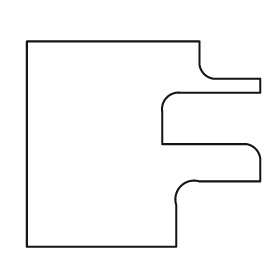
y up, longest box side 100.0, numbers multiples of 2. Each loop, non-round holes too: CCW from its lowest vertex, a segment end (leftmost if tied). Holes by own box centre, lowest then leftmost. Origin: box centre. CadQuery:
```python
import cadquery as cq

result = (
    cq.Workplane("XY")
    .moveTo(-50.0, -44.0)
    .lineTo(14.0, -44.0)
    .lineTo(14.0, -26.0)
    .threePointArc((16.0, -18.0), (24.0, -16.0))
    .lineTo(50.0, -16.0)
    .lineTo(50.0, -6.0)
    .threePointArc((48.0, -2.0), (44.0, 0.0))
    .lineTo(8.0, 0.0)
    .lineTo(8.0, 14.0)
    .threePointArc((10.0, 20.0), (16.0, 22.0))
    .lineTo(50.0, 22.0)
    .lineTo(50.0, 28.0)
    .lineTo(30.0, 28.0)
    .threePointArc((26.0, 30.0), (24.0, 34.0))
    .lineTo(24.0, 44.0)
    .lineTo(-50.0, 44.0)
    .close()
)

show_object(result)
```